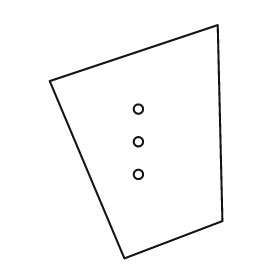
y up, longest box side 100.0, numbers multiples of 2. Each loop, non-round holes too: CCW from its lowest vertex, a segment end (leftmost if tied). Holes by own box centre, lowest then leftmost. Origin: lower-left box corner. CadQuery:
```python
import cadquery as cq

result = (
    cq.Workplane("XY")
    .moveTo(32.0, 0.0)
    .lineTo(74.0, 16.0)
    .lineTo(72.0, 100.0)
    .lineTo(0.0, 76.0)
    .close()
    .moveTo(38.0, 36.0)
    .circle(2.0)
    .moveTo(38.0, 50.0)
    .circle(2.0)
    .moveTo(38.0, 64.0)
    .circle(2.0)
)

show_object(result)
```